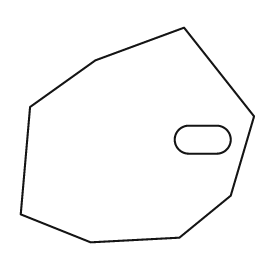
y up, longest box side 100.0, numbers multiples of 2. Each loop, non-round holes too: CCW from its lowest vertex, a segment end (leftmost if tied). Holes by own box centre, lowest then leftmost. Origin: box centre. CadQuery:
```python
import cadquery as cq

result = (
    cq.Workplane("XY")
    .moveTo(-20.0, -46.0)
    .lineTo(18.0, -44.0)
    .lineTo(40.0, -26.0)
    .lineTo(50.0, 8.0)
    .lineTo(20.0, 46.0)
    .lineTo(-18.0, 32.0)
    .lineTo(-46.0, 12.0)
    .lineTo(-50.0, -34.0)
    .close()
    .moveTo(22.0, -8.0)
    .lineTo(34.0, -8.0)
    .threePointArc((40.0, -2.0), (34.0, 4.0))
    .lineTo(22.0, 4.0)
    .threePointArc((16.0, -2.0), (22.0, -8.0))
    .close()
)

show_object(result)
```